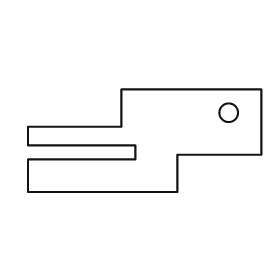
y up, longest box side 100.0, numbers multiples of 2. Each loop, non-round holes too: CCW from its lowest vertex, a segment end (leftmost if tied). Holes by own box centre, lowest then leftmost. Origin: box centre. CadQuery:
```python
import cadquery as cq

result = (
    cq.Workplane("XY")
    .moveTo(-50.0, -22.0)
    .lineTo(14.0, -22.0)
    .lineTo(14.0, -6.0)
    .lineTo(50.0, -6.0)
    .lineTo(50.0, 22.0)
    .lineTo(-10.0, 22.0)
    .lineTo(-10.0, 6.0)
    .lineTo(-50.0, 6.0)
    .lineTo(-50.0, -2.0)
    .lineTo(-4.0, -2.0)
    .lineTo(-4.0, -8.0)
    .lineTo(-50.0, -8.0)
    .close()
    .moveTo(36.0, 12.0)
    .circle(4.0)
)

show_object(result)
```